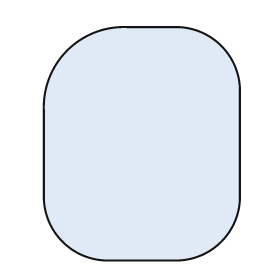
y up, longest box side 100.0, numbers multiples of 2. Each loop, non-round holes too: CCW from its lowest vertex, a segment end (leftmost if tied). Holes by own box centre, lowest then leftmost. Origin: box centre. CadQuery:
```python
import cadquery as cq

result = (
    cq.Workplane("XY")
    .moveTo(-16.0, -50.0)
    .lineTo(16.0, -50.0)
    .threePointArc((34.0, -42.0), (42.0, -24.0))
    .lineTo(42.0, 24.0)
    .threePointArc((34.0, 42.0), (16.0, 50.0))
    .lineTo(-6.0, 50.0)
    .threePointArc((-32.0, 40.0), (-42.0, 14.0))
    .lineTo(-42.0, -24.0)
    .threePointArc((-34.0, -42.0), (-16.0, -50.0))
    .close()
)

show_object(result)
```